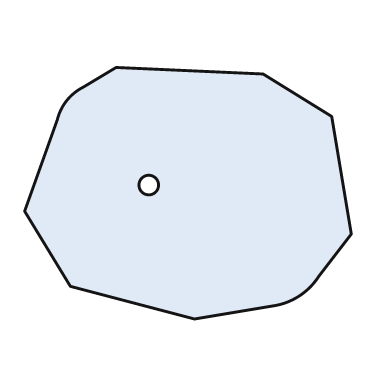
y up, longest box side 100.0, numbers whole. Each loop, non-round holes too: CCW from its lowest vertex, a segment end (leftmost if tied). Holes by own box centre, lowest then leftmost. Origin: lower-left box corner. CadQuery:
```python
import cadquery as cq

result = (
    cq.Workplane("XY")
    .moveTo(52.0, 0.0)
    .lineTo(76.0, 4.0)
    .threePointArc((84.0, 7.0), (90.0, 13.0))
    .lineTo(100.0, 26.0)
    .lineTo(94.0, 62.0)
    .lineTo(73.0, 75.0)
    .lineTo(28.0, 77.0)
    .lineTo(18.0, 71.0)
    .threePointArc((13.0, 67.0), (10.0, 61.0))
    .lineTo(0.0, 33.0)
    .lineTo(14.0, 10.0)
    .close()
    .moveTo(38.0, 41.0)
    .circle(3.0)
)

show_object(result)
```